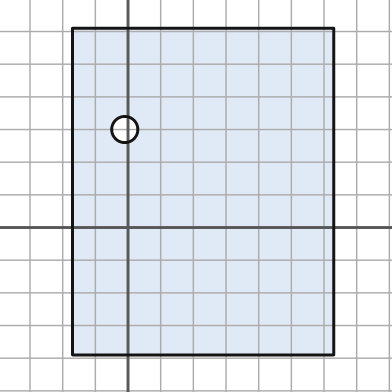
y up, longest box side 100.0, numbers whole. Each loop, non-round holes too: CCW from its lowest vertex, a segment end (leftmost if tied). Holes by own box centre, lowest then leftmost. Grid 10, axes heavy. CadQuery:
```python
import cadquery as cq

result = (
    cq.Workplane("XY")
    .moveTo(-17.0, -39.0)
    .lineTo(63.0, -39.0)
    .lineTo(63.0, 61.0)
    .lineTo(-17.0, 61.0)
    .close()
    .moveTo(-1.0, 30.0)
    .circle(4.0)
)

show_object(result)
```